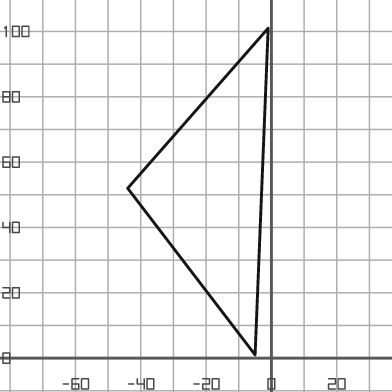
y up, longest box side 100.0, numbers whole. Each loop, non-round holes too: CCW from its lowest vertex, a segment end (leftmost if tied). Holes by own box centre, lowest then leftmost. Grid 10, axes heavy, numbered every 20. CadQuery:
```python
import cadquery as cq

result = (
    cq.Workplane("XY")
    .moveTo(-5.0, 1.0)
    .lineTo(-1.0, 101.0)
    .lineTo(-44.0, 52.0)
    .close()
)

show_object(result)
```